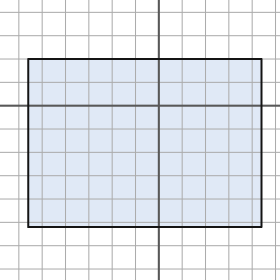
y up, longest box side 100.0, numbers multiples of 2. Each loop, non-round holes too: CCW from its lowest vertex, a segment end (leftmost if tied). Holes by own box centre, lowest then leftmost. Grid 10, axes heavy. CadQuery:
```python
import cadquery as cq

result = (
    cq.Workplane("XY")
    .moveTo(-56.0, -52.0)
    .lineTo(44.0, -52.0)
    .lineTo(44.0, 20.0)
    .lineTo(-56.0, 20.0)
    .close()
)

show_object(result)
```